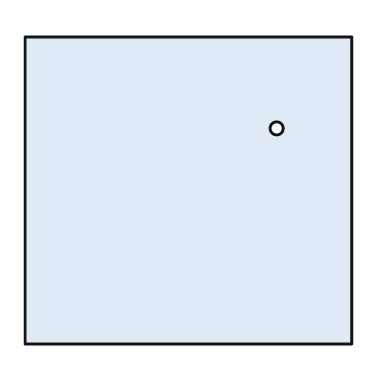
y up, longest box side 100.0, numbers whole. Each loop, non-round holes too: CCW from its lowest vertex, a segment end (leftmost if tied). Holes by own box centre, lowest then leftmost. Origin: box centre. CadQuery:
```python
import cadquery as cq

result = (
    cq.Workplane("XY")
    .moveTo(-50.0, -47.0)
    .lineTo(50.0, -47.0)
    .lineTo(50.0, 47.0)
    .lineTo(-50.0, 47.0)
    .close()
    .moveTo(27.0, 19.0)
    .circle(2.0)
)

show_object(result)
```